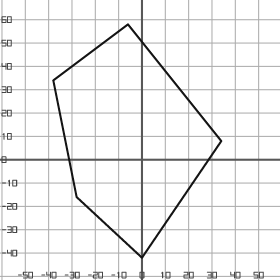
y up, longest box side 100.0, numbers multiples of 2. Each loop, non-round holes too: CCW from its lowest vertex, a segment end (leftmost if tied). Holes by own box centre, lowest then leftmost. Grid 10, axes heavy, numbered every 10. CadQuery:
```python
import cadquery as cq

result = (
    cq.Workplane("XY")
    .moveTo(0.0, -42.0)
    .lineTo(34.0, 8.0)
    .lineTo(-6.0, 58.0)
    .lineTo(-38.0, 34.0)
    .lineTo(-28.0, -16.0)
    .close()
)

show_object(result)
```